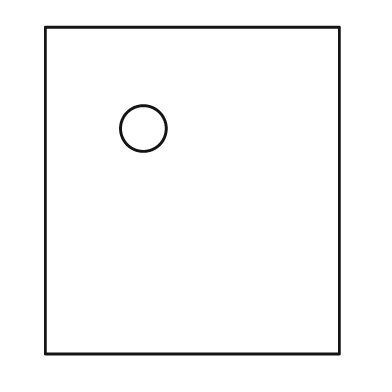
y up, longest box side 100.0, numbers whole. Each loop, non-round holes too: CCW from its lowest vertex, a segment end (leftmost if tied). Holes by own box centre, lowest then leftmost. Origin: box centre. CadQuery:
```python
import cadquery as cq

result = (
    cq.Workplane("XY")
    .moveTo(-45.0, -50.0)
    .lineTo(45.0, -50.0)
    .lineTo(45.0, 50.0)
    .lineTo(-45.0, 50.0)
    .close()
    .moveTo(-15.0, 19.0)
    .circle(7.0)
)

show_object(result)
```